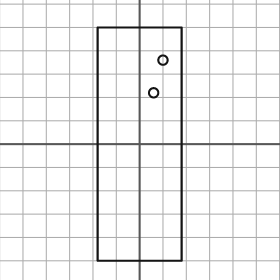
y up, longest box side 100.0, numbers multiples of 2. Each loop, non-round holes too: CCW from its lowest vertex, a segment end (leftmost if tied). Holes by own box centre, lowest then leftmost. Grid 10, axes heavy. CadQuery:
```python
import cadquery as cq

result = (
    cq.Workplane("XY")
    .moveTo(-18.0, -50.0)
    .lineTo(18.0, -50.0)
    .lineTo(18.0, 50.0)
    .lineTo(-18.0, 50.0)
    .close()
    .moveTo(6.0, 22.0)
    .circle(2.0)
    .moveTo(10.0, 36.0)
    .circle(2.0)
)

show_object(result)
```